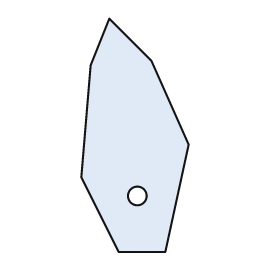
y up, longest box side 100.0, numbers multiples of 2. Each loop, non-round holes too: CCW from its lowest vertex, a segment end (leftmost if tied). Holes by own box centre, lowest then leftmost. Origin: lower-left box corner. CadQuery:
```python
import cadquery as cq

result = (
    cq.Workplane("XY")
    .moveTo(16.0, 0.0)
    .lineTo(36.0, 0.0)
    .lineTo(46.0, 46.0)
    .lineTo(30.0, 82.0)
    .lineTo(12.0, 100.0)
    .lineTo(4.0, 80.0)
    .lineTo(0.0, 32.0)
    .close()
    .moveTo(24.0, 24.0)
    .circle(4.0)
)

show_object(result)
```